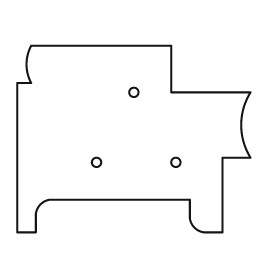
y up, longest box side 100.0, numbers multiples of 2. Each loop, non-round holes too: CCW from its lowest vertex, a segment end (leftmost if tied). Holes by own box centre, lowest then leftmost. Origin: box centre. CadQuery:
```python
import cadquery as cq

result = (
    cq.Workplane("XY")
    .moveTo(-50.0, -40.0)
    .lineTo(-42.0, -40.0)
    .lineTo(-42.0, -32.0)
    .threePointArc((-40.0, -28.0), (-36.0, -26.0))
    .lineTo(24.0, -26.0)
    .lineTo(24.0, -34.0)
    .threePointArc((26.0, -38.0), (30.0, -40.0))
    .lineTo(38.0, -40.0)
    .lineTo(38.0, -8.0)
    .lineTo(50.0, -8.0)
    .threePointArc((46.0, 6.0), (50.0, 20.0))
    .lineTo(16.0, 20.0)
    .lineTo(16.0, 40.0)
    .lineTo(-44.0, 40.0)
    .threePointArc((-46.0, 32.0), (-44.0, 24.0))
    .lineTo(-50.0, 24.0)
    .close()
    .moveTo(-16.0, -10.0)
    .circle(2.0)
    .moveTo(18.0, -10.0)
    .circle(2.0)
    .moveTo(0.0, 20.0)
    .circle(2.0)
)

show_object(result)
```